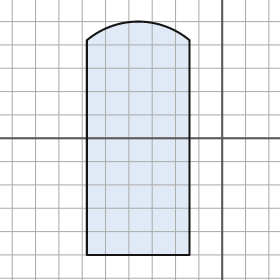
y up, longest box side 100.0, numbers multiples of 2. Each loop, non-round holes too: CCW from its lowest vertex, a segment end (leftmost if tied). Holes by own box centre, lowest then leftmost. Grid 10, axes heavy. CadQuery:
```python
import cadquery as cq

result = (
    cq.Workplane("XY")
    .moveTo(-58.0, -50.0)
    .lineTo(-14.0, -50.0)
    .lineTo(-14.0, 42.0)
    .threePointArc((-36.0, 50.0), (-58.0, 42.0))
    .close()
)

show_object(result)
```